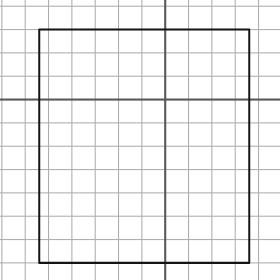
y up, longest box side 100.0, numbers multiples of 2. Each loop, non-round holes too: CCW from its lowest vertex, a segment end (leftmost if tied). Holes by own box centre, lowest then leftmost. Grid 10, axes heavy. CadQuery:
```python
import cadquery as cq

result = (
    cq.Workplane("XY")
    .moveTo(-54.0, -70.0)
    .lineTo(36.0, -70.0)
    .lineTo(36.0, 30.0)
    .lineTo(-54.0, 30.0)
    .close()
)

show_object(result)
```